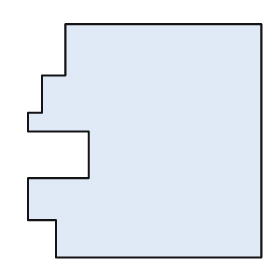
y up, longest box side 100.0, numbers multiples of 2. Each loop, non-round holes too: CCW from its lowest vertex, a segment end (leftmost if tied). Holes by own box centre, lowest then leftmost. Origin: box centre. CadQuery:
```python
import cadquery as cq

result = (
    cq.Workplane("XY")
    .moveTo(-38.0, -50.0)
    .lineTo(50.0, -50.0)
    .lineTo(50.0, 50.0)
    .lineTo(-34.0, 50.0)
    .lineTo(-34.0, 28.0)
    .lineTo(-44.0, 28.0)
    .lineTo(-44.0, 12.0)
    .lineTo(-50.0, 12.0)
    .lineTo(-50.0, 4.0)
    .lineTo(-24.0, 4.0)
    .lineTo(-24.0, -16.0)
    .lineTo(-50.0, -16.0)
    .lineTo(-50.0, -34.0)
    .lineTo(-38.0, -34.0)
    .close()
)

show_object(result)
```